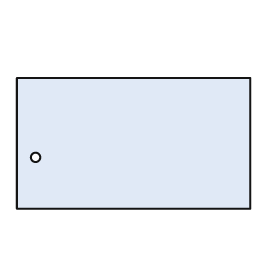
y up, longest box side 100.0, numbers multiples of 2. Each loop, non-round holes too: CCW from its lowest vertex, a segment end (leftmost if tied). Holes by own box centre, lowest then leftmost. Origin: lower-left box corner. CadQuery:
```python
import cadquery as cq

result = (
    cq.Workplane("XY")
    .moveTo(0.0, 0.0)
    .lineTo(100.0, 0.0)
    .lineTo(100.0, 56.0)
    .lineTo(0.0, 56.0)
    .close()
    .moveTo(8.0, 22.0)
    .circle(2.0)
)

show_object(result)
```